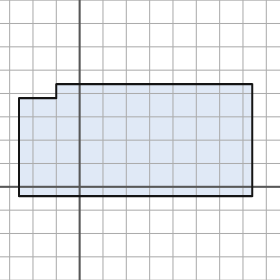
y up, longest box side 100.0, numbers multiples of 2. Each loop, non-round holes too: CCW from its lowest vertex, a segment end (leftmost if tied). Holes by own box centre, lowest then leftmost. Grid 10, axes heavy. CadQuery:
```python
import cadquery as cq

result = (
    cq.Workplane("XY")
    .moveTo(-26.0, -4.0)
    .lineTo(74.0, -4.0)
    .lineTo(74.0, 44.0)
    .lineTo(-10.0, 44.0)
    .lineTo(-10.0, 38.0)
    .lineTo(-26.0, 38.0)
    .close()
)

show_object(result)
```